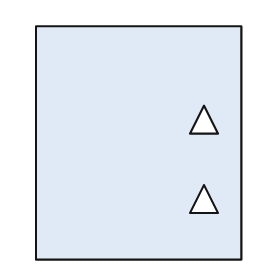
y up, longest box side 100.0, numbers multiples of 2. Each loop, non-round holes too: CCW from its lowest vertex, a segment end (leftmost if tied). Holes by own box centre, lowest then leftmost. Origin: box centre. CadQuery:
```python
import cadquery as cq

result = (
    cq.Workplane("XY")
    .moveTo(-44.0, -50.0)
    .lineTo(44.0, -50.0)
    .lineTo(44.0, 50.0)
    .lineTo(-44.0, 50.0)
    .close()
    .moveTo(22.0, -30.0)
    .lineTo(34.0, -30.0)
    .lineTo(28.0, -18.0)
    .close()
    .moveTo(22.0, 4.0)
    .lineTo(34.0, 4.0)
    .lineTo(28.0, 16.0)
    .close()
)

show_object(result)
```